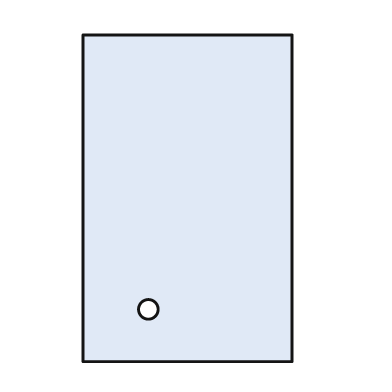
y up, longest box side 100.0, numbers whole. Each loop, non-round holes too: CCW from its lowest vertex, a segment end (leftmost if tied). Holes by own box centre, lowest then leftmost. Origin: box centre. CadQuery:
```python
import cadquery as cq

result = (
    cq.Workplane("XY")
    .moveTo(-32.0, -50.0)
    .lineTo(32.0, -50.0)
    .lineTo(32.0, 50.0)
    .lineTo(-32.0, 50.0)
    .close()
    .moveTo(-12.0, -34.0)
    .circle(3.0)
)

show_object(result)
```